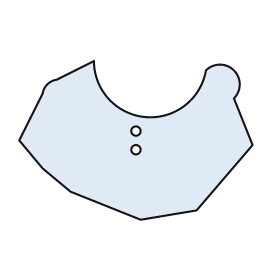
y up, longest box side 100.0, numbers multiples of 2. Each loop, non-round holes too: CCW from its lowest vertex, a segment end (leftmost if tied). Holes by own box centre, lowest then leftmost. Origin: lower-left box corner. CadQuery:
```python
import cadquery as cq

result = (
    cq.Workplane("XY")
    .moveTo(52.0, 0.0)
    .lineTo(76.0, 4.0)
    .lineTo(100.0, 32.0)
    .lineTo(92.0, 52.0)
    .threePointArc((92.0, 64.0), (80.0, 64.0))
    .threePointArc((54.0, 44.0), (32.0, 68.0))
    .lineTo(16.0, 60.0)
    .threePointArc((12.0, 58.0), (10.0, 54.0))
    .lineTo(0.0, 34.0)
    .lineTo(10.0, 22.0)
    .lineTo(22.0, 12.0)
    .close()
    .moveTo(50.0, 30.0)
    .circle(2.0)
    .moveTo(50.0, 38.0)
    .circle(2.0)
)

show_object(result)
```